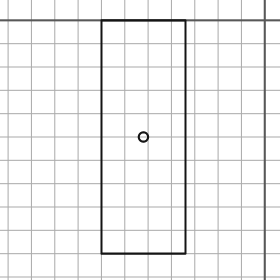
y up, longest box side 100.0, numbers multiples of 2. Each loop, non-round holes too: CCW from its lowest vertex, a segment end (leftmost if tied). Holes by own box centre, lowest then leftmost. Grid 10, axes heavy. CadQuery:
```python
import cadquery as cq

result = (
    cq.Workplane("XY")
    .moveTo(-70.0, -100.0)
    .lineTo(-34.0, -100.0)
    .lineTo(-34.0, 0.0)
    .lineTo(-70.0, 0.0)
    .close()
    .moveTo(-52.0, -50.0)
    .circle(2.0)
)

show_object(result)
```